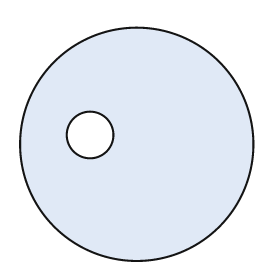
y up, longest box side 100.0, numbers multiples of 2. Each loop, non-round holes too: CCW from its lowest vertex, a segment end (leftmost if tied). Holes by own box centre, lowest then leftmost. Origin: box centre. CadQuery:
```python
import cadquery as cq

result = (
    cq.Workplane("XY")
    .moveTo(0.0, 0.0)
    .circle(50.0)
    .moveTo(-20.0, 4.0)
    .circle(10.0)
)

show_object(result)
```